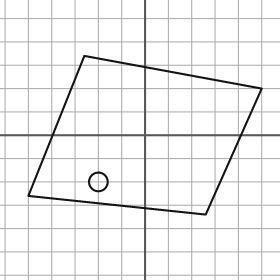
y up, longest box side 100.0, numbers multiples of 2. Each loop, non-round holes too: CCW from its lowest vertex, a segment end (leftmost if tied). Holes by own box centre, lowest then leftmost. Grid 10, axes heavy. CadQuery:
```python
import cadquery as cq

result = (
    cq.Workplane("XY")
    .moveTo(26.0, -34.0)
    .lineTo(50.0, 20.0)
    .lineTo(-26.0, 34.0)
    .lineTo(-50.0, -26.0)
    .close()
    .moveTo(-20.0, -20.0)
    .circle(4.0)
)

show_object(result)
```